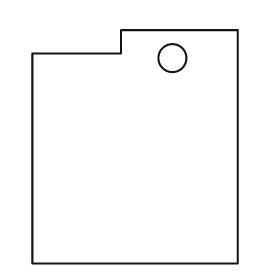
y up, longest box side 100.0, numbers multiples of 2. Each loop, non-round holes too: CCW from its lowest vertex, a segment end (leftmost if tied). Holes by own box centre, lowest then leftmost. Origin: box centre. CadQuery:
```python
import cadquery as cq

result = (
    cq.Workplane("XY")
    .moveTo(-44.0, -50.0)
    .lineTo(44.0, -50.0)
    .lineTo(44.0, 50.0)
    .lineTo(-6.0, 50.0)
    .lineTo(-6.0, 40.0)
    .lineTo(-44.0, 40.0)
    .close()
    .moveTo(16.0, 38.0)
    .circle(6.0)
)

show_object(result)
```